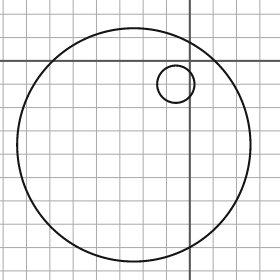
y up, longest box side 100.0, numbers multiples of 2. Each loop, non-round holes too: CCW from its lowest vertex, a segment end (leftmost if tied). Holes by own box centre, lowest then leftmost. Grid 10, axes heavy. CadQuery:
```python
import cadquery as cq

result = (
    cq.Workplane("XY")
    .moveTo(-24.0, -36.0)
    .circle(50.0)
    .moveTo(-6.0, -10.0)
    .circle(8.0)
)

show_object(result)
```